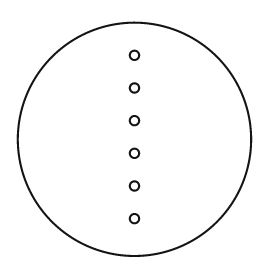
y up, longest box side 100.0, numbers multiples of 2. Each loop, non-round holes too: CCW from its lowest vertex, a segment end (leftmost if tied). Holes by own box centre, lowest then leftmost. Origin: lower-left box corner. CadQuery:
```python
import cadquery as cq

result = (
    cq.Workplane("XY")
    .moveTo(50.0, 50.0)
    .circle(50.0)
    .moveTo(50.0, 16.0)
    .circle(2.0)
    .moveTo(50.0, 30.0)
    .circle(2.0)
    .moveTo(50.0, 44.0)
    .circle(2.0)
    .moveTo(50.0, 58.0)
    .circle(2.0)
    .moveTo(50.0, 72.0)
    .circle(2.0)
    .moveTo(50.0, 86.0)
    .circle(2.0)
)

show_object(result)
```